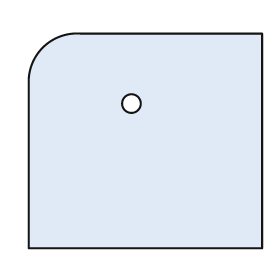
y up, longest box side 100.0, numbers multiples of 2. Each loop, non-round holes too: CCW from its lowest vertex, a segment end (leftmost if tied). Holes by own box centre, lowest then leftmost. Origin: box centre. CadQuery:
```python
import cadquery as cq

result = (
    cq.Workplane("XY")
    .moveTo(-50.0, -46.0)
    .lineTo(50.0, -46.0)
    .lineTo(50.0, 46.0)
    .lineTo(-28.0, 46.0)
    .threePointArc((-44.0, 40.0), (-50.0, 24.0))
    .close()
    .moveTo(-6.0, 16.0)
    .circle(4.0)
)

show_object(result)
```